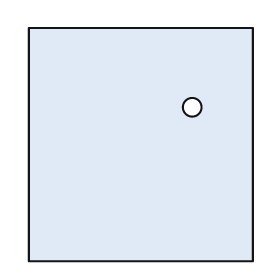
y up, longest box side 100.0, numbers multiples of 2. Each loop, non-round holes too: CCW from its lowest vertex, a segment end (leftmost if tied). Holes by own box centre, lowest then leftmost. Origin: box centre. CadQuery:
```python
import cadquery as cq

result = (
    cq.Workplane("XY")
    .moveTo(-48.0, -50.0)
    .lineTo(48.0, -50.0)
    .lineTo(48.0, 50.0)
    .lineTo(-48.0, 50.0)
    .close()
    .moveTo(22.0, 16.0)
    .circle(4.0)
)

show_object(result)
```